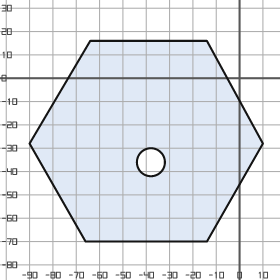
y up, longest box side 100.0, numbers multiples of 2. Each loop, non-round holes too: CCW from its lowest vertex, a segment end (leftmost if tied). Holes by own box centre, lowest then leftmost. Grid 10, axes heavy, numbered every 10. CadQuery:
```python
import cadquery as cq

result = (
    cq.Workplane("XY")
    .moveTo(-66.0, -70.0)
    .lineTo(-14.0, -70.0)
    .lineTo(10.0, -28.0)
    .lineTo(-14.0, 16.0)
    .lineTo(-64.0, 16.0)
    .lineTo(-90.0, -28.0)
    .close()
    .moveTo(-38.0, -36.0)
    .circle(6.0)
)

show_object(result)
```